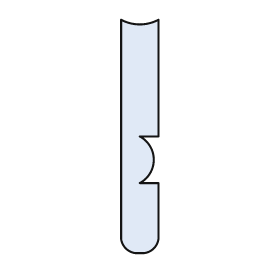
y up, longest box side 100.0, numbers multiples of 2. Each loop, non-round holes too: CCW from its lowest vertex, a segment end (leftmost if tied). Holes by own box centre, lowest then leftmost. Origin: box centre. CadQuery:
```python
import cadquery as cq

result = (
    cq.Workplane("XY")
    .moveTo(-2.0, -50.0)
    .lineTo(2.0, -50.0)
    .threePointArc((6.0, -48.0), (8.0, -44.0))
    .lineTo(8.0, -20.0)
    .lineTo(0.0, -20.0)
    .threePointArc((6.0, -10.0), (0.0, 0.0))
    .lineTo(8.0, 0.0)
    .lineTo(8.0, 50.0)
    .threePointArc((0.0, 48.0), (-8.0, 50.0))
    .lineTo(-8.0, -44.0)
    .threePointArc((-6.0, -48.0), (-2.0, -50.0))
    .close()
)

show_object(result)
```